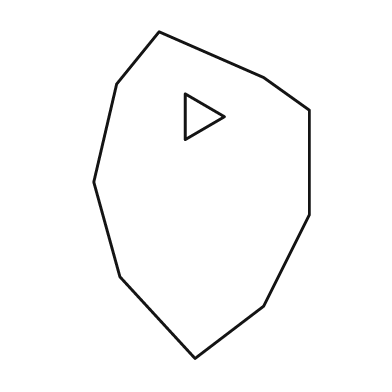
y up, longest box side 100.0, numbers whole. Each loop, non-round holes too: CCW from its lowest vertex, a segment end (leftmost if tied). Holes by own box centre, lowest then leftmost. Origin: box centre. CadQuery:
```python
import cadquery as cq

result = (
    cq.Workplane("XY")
    .moveTo(-2.0, -50.0)
    .lineTo(19.0, -34.0)
    .lineTo(33.0, -6.0)
    .lineTo(33.0, 26.0)
    .lineTo(19.0, 36.0)
    .lineTo(-13.0, 50.0)
    .lineTo(-26.0, 34.0)
    .lineTo(-33.0, 4.0)
    .lineTo(-25.0, -25.0)
    .close()
    .moveTo(-5.0, 17.0)
    .lineTo(7.0, 24.0)
    .lineTo(-5.0, 31.0)
    .close()
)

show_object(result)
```